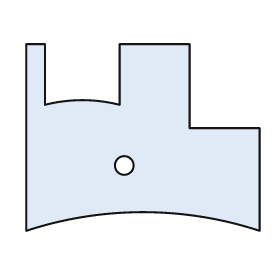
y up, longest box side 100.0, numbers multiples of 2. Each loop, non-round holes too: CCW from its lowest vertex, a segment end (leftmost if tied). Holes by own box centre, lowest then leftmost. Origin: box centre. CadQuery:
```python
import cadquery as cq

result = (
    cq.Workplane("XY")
    .moveTo(-50.0, -40.0)
    .threePointArc((0.0, -32.0), (50.0, -40.0))
    .lineTo(50.0, 4.0)
    .lineTo(20.0, 4.0)
    .lineTo(20.0, 40.0)
    .lineTo(-10.0, 40.0)
    .lineTo(-10.0, 14.0)
    .threePointArc((-26.0, 16.0), (-42.0, 14.0))
    .lineTo(-42.0, 40.0)
    .lineTo(-50.0, 40.0)
    .close()
    .moveTo(-8.0, -12.0)
    .circle(4.0)
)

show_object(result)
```